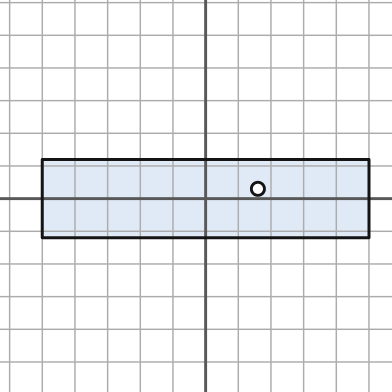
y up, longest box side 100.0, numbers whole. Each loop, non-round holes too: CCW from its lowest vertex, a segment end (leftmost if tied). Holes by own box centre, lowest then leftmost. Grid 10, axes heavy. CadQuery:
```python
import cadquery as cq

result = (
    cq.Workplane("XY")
    .moveTo(-50.0, -12.0)
    .lineTo(50.0, -12.0)
    .lineTo(50.0, 12.0)
    .lineTo(-50.0, 12.0)
    .close()
    .moveTo(16.0, 3.0)
    .circle(2.0)
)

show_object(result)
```